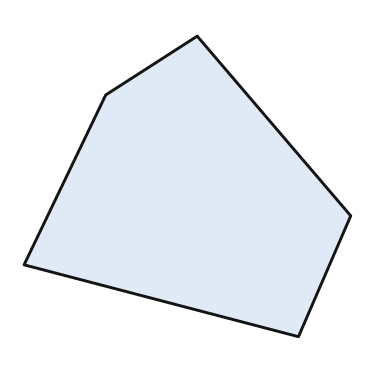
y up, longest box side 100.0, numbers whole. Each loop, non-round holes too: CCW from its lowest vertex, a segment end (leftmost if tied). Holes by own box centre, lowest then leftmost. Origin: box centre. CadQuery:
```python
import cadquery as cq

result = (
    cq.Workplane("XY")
    .moveTo(34.0, -46.0)
    .lineTo(50.0, -9.0)
    .lineTo(3.0, 46.0)
    .lineTo(-25.0, 28.0)
    .lineTo(-50.0, -24.0)
    .close()
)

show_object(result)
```